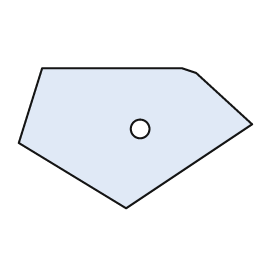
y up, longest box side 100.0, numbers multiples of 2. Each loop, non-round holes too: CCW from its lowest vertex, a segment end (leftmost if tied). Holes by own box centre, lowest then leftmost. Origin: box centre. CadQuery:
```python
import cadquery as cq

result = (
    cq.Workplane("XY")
    .moveTo(-4.0, -30.0)
    .lineTo(50.0, 6.0)
    .lineTo(26.0, 28.0)
    .lineTo(20.0, 30.0)
    .lineTo(-40.0, 30.0)
    .lineTo(-50.0, -2.0)
    .close()
    .moveTo(2.0, 4.0)
    .circle(4.0)
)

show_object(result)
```